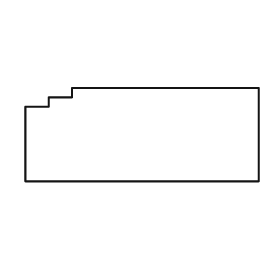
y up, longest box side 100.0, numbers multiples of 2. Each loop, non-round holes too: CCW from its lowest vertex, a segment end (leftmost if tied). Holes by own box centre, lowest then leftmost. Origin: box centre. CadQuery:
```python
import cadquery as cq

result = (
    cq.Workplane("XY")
    .moveTo(-50.0, -20.0)
    .lineTo(50.0, -20.0)
    .lineTo(50.0, 20.0)
    .lineTo(-30.0, 20.0)
    .lineTo(-30.0, 16.0)
    .lineTo(-40.0, 16.0)
    .lineTo(-40.0, 12.0)
    .lineTo(-50.0, 12.0)
    .close()
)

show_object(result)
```